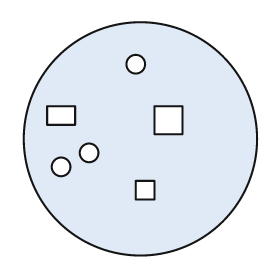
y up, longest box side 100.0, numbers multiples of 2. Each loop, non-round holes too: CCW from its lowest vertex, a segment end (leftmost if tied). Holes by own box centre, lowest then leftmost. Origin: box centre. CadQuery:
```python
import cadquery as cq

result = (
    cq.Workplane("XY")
    .moveTo(0.0, 0.0)
    .circle(50.0)
    .moveTo(-2.0, -26.0)
    .lineTo(6.0, -26.0)
    .lineTo(6.0, -18.0)
    .lineTo(-2.0, -18.0)
    .close()
    .moveTo(-34.0, -12.0)
    .circle(4.0)
    .moveTo(-22.0, -6.0)
    .circle(4.0)
    .moveTo(6.0, 2.0)
    .lineTo(18.0, 2.0)
    .lineTo(18.0, 14.0)
    .lineTo(6.0, 14.0)
    .close()
    .moveTo(-40.0, 6.0)
    .lineTo(-28.0, 6.0)
    .lineTo(-28.0, 14.0)
    .lineTo(-40.0, 14.0)
    .close()
    .moveTo(-2.0, 32.0)
    .circle(4.0)
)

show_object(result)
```